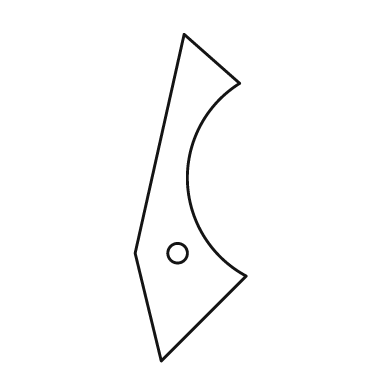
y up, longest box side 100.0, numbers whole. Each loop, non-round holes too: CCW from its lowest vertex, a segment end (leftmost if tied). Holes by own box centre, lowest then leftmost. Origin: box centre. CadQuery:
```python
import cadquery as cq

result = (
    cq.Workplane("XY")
    .moveTo(-9.0, -50.0)
    .lineTo(17.0, -24.0)
    .threePointArc((-1.0, 5.0), (15.0, 35.0))
    .lineTo(-2.0, 50.0)
    .lineTo(-17.0, -17.0)
    .close()
    .moveTo(-4.0, -17.0)
    .circle(3.0)
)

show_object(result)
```